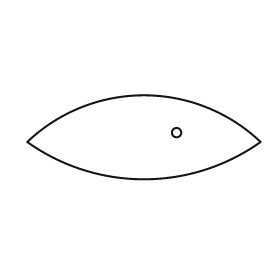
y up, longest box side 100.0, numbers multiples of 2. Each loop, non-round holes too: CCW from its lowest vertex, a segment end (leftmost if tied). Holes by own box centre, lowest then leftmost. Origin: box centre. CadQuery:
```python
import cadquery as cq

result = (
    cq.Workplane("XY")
    .moveTo(-50.0, -2.0)
    .threePointArc((0.0, -18.0), (50.0, -2.0))
    .threePointArc((0.0, 18.0), (-50.0, -2.0))
    .close()
    .moveTo(14.0, 2.0)
    .circle(2.0)
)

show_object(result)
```